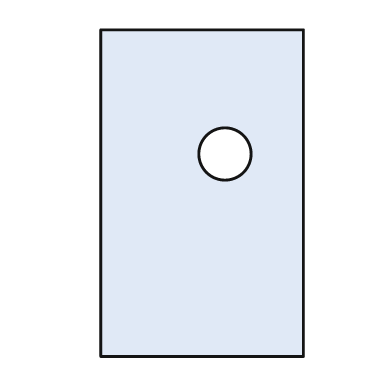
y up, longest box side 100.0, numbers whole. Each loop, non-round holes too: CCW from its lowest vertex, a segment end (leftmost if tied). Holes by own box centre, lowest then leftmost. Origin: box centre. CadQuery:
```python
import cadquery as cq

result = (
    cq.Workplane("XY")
    .moveTo(-31.0, -50.0)
    .lineTo(31.0, -50.0)
    .lineTo(31.0, 50.0)
    .lineTo(-31.0, 50.0)
    .close()
    .moveTo(7.0, 12.0)
    .circle(8.0)
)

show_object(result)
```